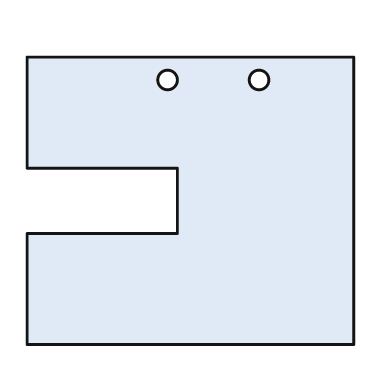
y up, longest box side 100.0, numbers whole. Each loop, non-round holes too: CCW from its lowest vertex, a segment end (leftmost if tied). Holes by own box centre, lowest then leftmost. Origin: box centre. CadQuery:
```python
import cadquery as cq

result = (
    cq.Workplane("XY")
    .moveTo(-50.0, -44.0)
    .lineTo(50.0, -44.0)
    .lineTo(50.0, 44.0)
    .lineTo(-50.0, 44.0)
    .lineTo(-50.0, 10.0)
    .lineTo(-4.0, 10.0)
    .lineTo(-4.0, -10.0)
    .lineTo(-50.0, -10.0)
    .close()
    .moveTo(-7.0, 37.0)
    .circle(3.0)
    .moveTo(21.0, 37.0)
    .circle(3.0)
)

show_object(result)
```